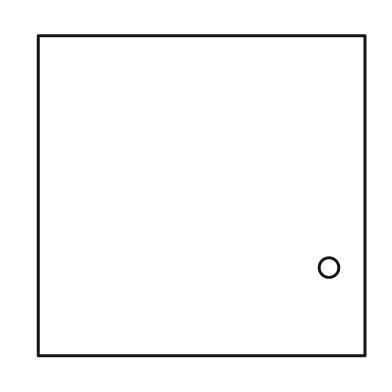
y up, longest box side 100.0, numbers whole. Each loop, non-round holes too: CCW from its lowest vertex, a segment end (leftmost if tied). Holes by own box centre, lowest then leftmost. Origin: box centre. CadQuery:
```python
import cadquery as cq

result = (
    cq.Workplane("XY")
    .moveTo(-50.0, -49.0)
    .lineTo(50.0, -49.0)
    .lineTo(50.0, 49.0)
    .lineTo(-50.0, 49.0)
    .close()
    .moveTo(39.0, -22.0)
    .circle(3.0)
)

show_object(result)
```